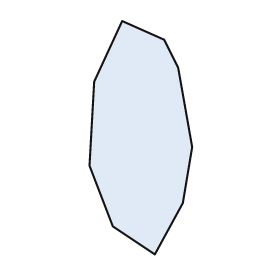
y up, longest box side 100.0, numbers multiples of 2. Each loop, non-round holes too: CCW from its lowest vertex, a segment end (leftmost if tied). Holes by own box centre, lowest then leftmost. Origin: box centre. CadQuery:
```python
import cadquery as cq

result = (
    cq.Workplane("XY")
    .moveTo(6.0, -50.0)
    .lineTo(18.0, -28.0)
    .lineTo(22.0, -4.0)
    .lineTo(16.0, 30.0)
    .lineTo(10.0, 42.0)
    .lineTo(-8.0, 50.0)
    .lineTo(-20.0, 24.0)
    .lineTo(-22.0, -12.0)
    .lineTo(-12.0, -38.0)
    .close()
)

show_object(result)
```